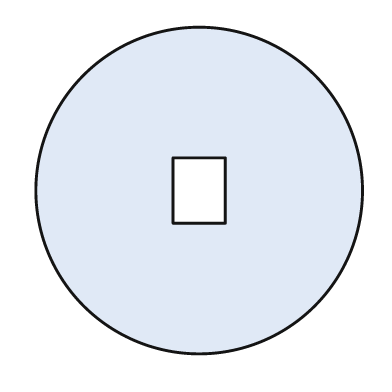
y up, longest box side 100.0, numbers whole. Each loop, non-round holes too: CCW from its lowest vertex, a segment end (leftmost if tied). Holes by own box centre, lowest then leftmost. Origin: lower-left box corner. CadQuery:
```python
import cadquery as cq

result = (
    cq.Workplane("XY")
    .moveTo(50.0, 50.0)
    .circle(50.0)
    .moveTo(42.0, 40.0)
    .lineTo(58.0, 40.0)
    .lineTo(58.0, 60.0)
    .lineTo(42.0, 60.0)
    .close()
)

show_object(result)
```